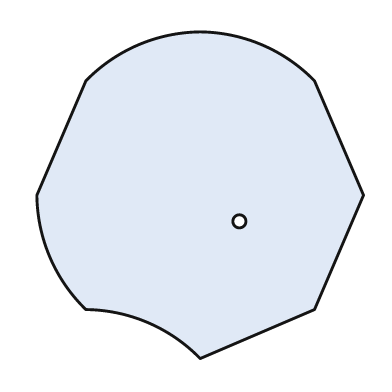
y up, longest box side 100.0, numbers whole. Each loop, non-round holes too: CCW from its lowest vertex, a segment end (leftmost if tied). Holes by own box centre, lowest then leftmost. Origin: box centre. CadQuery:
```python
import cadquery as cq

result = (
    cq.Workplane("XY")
    .moveTo(0.0, -50.0)
    .lineTo(35.0, -35.0)
    .lineTo(50.0, 0.0)
    .lineTo(35.0, 35.0)
    .threePointArc((19.0, 46.0), (0.0, 50.0))
    .threePointArc((-19.0, 46.0), (-35.0, 35.0))
    .lineTo(-50.0, 0.0)
    .threePointArc((-46.0, -19.0), (-35.0, -35.0))
    .threePointArc((-16.0, -39.0), (0.0, -50.0))
    .close()
    .moveTo(12.0, -8.0)
    .circle(2.0)
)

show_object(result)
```